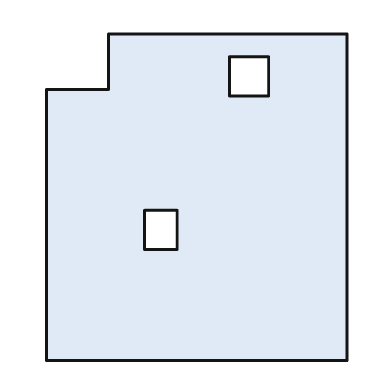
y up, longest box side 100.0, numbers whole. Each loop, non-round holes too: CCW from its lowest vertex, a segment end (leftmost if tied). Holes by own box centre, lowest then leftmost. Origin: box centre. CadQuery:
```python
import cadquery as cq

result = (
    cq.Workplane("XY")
    .moveTo(-46.0, -50.0)
    .lineTo(46.0, -50.0)
    .lineTo(46.0, 50.0)
    .lineTo(-27.0, 50.0)
    .lineTo(-27.0, 33.0)
    .lineTo(-46.0, 33.0)
    .close()
    .moveTo(-16.0, -16.0)
    .lineTo(-6.0, -16.0)
    .lineTo(-6.0, -4.0)
    .lineTo(-16.0, -4.0)
    .close()
    .moveTo(10.0, 31.0)
    .lineTo(22.0, 31.0)
    .lineTo(22.0, 43.0)
    .lineTo(10.0, 43.0)
    .close()
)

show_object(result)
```